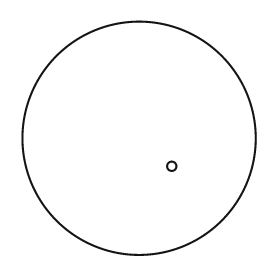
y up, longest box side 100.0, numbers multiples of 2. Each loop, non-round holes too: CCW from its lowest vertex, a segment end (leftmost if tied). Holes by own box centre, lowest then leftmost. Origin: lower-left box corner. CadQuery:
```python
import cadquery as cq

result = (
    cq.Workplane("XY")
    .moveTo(50.0, 50.0)
    .circle(50.0)
    .moveTo(64.0, 38.0)
    .circle(2.0)
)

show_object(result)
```